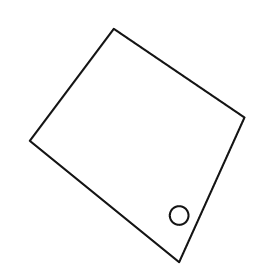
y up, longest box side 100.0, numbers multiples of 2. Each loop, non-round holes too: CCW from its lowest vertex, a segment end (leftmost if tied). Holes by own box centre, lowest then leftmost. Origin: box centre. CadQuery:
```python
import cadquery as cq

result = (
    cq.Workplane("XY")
    .moveTo(18.0, -50.0)
    .lineTo(46.0, 12.0)
    .lineTo(-10.0, 50.0)
    .lineTo(-46.0, 2.0)
    .close()
    .moveTo(18.0, -30.0)
    .circle(4.0)
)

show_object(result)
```